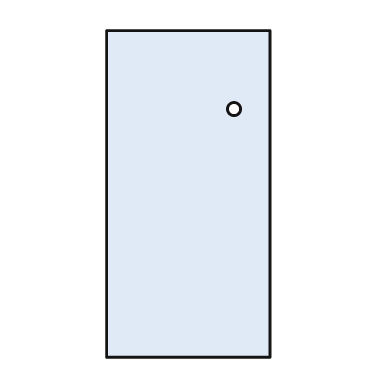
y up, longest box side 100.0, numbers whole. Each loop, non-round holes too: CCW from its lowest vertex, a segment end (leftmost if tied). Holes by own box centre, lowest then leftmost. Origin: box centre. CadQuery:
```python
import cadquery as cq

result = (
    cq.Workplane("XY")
    .moveTo(-25.0, -50.0)
    .lineTo(25.0, -50.0)
    .lineTo(25.0, 50.0)
    .lineTo(-25.0, 50.0)
    .close()
    .moveTo(14.0, 26.0)
    .circle(2.0)
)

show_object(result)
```